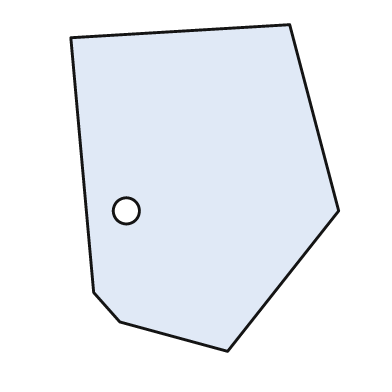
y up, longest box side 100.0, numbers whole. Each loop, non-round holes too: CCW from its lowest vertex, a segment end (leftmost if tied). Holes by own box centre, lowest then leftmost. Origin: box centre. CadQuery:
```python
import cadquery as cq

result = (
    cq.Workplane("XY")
    .moveTo(7.0, -50.0)
    .lineTo(41.0, -7.0)
    .lineTo(26.0, 50.0)
    .lineTo(-41.0, 46.0)
    .lineTo(-34.0, -32.0)
    .lineTo(-26.0, -41.0)
    .close()
    .moveTo(-24.0, -7.0)
    .circle(4.0)
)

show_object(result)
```